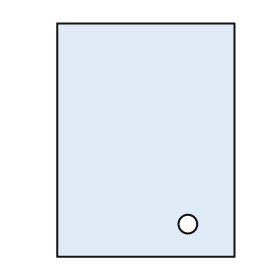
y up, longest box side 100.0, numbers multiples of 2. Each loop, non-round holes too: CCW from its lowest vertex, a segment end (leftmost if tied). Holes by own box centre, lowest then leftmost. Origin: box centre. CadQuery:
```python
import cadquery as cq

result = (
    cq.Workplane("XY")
    .moveTo(-38.0, -50.0)
    .lineTo(38.0, -50.0)
    .lineTo(38.0, 50.0)
    .lineTo(-38.0, 50.0)
    .close()
    .moveTo(18.0, -36.0)
    .circle(4.0)
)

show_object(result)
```